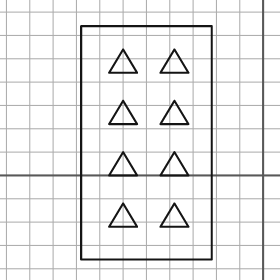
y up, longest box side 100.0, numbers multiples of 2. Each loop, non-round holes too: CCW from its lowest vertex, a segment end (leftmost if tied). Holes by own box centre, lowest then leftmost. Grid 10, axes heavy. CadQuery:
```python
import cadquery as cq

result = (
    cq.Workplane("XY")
    .moveTo(-78.0, -36.0)
    .lineTo(-22.0, -36.0)
    .lineTo(-22.0, 64.0)
    .lineTo(-78.0, 64.0)
    .close()
    .moveTo(-66.0, -22.0)
    .lineTo(-54.0, -22.0)
    .lineTo(-60.0, -12.0)
    .close()
    .moveTo(-44.0, -22.0)
    .lineTo(-32.0, -22.0)
    .lineTo(-38.0, -12.0)
    .close()
    .moveTo(-66.0, 0.0)
    .lineTo(-54.0, 0.0)
    .lineTo(-60.0, 10.0)
    .close()
    .moveTo(-44.0, 0.0)
    .lineTo(-32.0, 0.0)
    .lineTo(-38.0, 10.0)
    .close()
    .moveTo(-66.0, 22.0)
    .lineTo(-54.0, 22.0)
    .lineTo(-60.0, 32.0)
    .close()
    .moveTo(-44.0, 22.0)
    .lineTo(-32.0, 22.0)
    .lineTo(-38.0, 32.0)
    .close()
    .moveTo(-66.0, 44.0)
    .lineTo(-54.0, 44.0)
    .lineTo(-60.0, 54.0)
    .close()
    .moveTo(-44.0, 44.0)
    .lineTo(-32.0, 44.0)
    .lineTo(-38.0, 54.0)
    .close()
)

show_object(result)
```